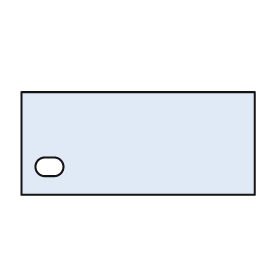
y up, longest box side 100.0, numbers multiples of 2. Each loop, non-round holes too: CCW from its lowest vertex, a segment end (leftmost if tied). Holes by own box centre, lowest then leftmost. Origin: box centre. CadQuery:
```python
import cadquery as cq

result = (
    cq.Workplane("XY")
    .moveTo(-50.0, -22.0)
    .lineTo(50.0, -22.0)
    .lineTo(50.0, 22.0)
    .lineTo(-50.0, 22.0)
    .close()
    .moveTo(-40.0, -14.0)
    .lineTo(-36.0, -14.0)
    .threePointArc((-32.0, -10.0), (-36.0, -6.0))
    .lineTo(-40.0, -6.0)
    .threePointArc((-44.0, -10.0), (-40.0, -14.0))
    .close()
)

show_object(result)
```